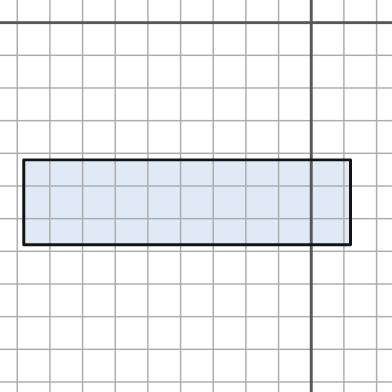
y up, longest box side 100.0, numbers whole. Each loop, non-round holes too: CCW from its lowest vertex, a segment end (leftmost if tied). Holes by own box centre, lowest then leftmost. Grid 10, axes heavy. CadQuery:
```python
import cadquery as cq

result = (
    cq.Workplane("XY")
    .moveTo(-88.0, -68.0)
    .lineTo(12.0, -68.0)
    .lineTo(12.0, -42.0)
    .lineTo(-88.0, -42.0)
    .close()
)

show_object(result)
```